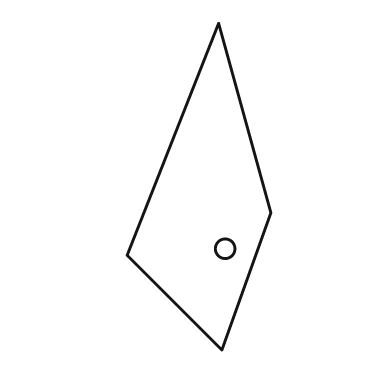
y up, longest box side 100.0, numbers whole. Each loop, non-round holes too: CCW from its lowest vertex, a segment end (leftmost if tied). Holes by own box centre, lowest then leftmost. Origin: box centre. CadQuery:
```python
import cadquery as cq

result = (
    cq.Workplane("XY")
    .moveTo(7.0, -50.0)
    .lineTo(22.0, -8.0)
    .lineTo(6.0, 50.0)
    .lineTo(-22.0, -21.0)
    .close()
    .moveTo(8.0, -19.0)
    .circle(3.0)
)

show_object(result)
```